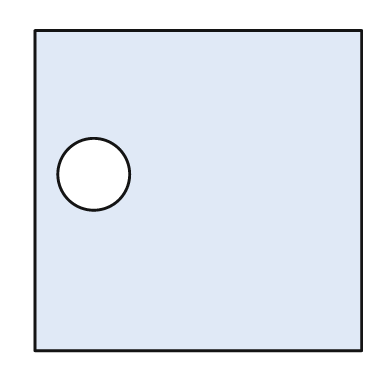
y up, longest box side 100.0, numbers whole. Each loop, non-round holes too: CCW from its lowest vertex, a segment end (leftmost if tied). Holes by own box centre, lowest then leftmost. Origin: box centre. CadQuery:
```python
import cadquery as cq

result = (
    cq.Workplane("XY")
    .moveTo(-50.0, -49.0)
    .lineTo(50.0, -49.0)
    .lineTo(50.0, 49.0)
    .lineTo(-50.0, 49.0)
    .close()
    .moveTo(-32.0, 5.0)
    .circle(11.0)
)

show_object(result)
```